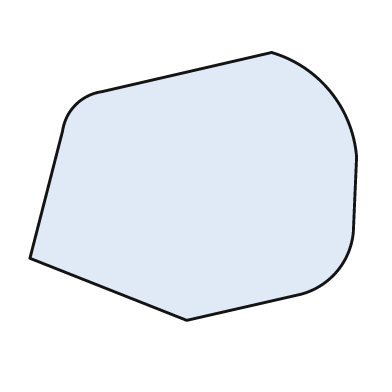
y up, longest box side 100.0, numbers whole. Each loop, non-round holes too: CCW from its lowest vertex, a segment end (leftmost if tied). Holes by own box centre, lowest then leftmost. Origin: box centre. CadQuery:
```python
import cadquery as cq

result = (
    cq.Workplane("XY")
    .moveTo(-2.0, -41.0)
    .lineTo(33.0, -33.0)
    .threePointArc((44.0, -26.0), (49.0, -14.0))
    .lineTo(50.0, 9.0)
    .threePointArc((42.0, 29.0), (24.0, 41.0))
    .lineTo(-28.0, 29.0)
    .threePointArc((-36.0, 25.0), (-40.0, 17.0))
    .lineTo(-50.0, -22.0)
    .close()
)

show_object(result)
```